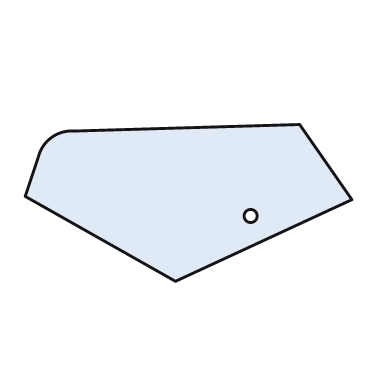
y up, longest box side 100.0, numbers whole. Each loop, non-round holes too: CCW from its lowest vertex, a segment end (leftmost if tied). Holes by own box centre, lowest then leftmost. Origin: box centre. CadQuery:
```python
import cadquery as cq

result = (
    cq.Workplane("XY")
    .moveTo(-4.0, -24.0)
    .lineTo(50.0, 1.0)
    .lineTo(34.0, 24.0)
    .lineTo(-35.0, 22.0)
    .threePointArc((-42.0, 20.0), (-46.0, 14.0))
    .lineTo(-50.0, 2.0)
    .close()
    .moveTo(19.0, -4.0)
    .circle(2.0)
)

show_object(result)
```